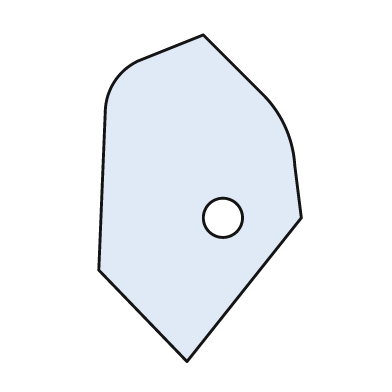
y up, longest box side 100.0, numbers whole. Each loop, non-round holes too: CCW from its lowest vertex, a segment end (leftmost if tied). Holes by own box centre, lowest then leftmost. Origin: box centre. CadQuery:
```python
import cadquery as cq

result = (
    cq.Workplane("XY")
    .moveTo(-4.0, -50.0)
    .lineTo(31.0, -6.0)
    .lineTo(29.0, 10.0)
    .threePointArc((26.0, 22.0), (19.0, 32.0))
    .lineTo(1.0, 50.0)
    .lineTo(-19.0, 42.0)
    .threePointArc((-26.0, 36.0), (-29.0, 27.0))
    .lineTo(-31.0, -22.0)
    .close()
    .moveTo(7.0, -6.0)
    .circle(6.0)
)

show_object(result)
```